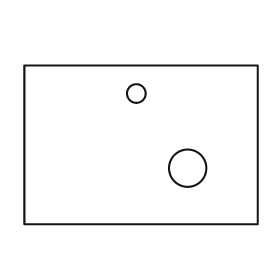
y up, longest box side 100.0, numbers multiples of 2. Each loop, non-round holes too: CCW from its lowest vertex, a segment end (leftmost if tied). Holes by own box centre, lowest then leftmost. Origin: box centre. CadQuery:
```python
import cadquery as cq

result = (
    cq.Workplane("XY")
    .moveTo(-50.0, -34.0)
    .lineTo(50.0, -34.0)
    .lineTo(50.0, 34.0)
    .lineTo(-50.0, 34.0)
    .close()
    .moveTo(20.0, -10.0)
    .circle(8.0)
    .moveTo(-2.0, 22.0)
    .circle(4.0)
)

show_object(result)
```